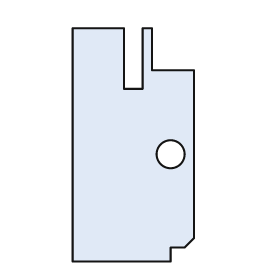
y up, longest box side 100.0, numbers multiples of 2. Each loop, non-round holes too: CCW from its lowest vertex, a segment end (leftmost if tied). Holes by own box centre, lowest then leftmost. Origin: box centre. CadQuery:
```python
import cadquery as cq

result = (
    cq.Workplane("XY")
    .moveTo(-26.0, -50.0)
    .lineTo(16.0, -50.0)
    .lineTo(16.0, -44.0)
    .lineTo(22.0, -44.0)
    .lineTo(26.0, -40.0)
    .lineTo(26.0, 32.0)
    .lineTo(8.0, 32.0)
    .lineTo(8.0, 50.0)
    .lineTo(4.0, 50.0)
    .lineTo(4.0, 24.0)
    .lineTo(-4.0, 24.0)
    .lineTo(-4.0, 50.0)
    .lineTo(-26.0, 50.0)
    .close()
    .moveTo(16.0, -4.0)
    .circle(6.0)
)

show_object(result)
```